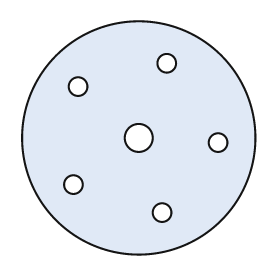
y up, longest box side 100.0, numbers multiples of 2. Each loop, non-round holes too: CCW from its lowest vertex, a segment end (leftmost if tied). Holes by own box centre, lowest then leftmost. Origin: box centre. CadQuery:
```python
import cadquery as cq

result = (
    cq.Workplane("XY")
    .moveTo(0.0, 0.0)
    .circle(50.0)
    .moveTo(10.0, -32.0)
    .circle(4.0)
    .moveTo(-28.0, -20.0)
    .circle(4.0)
    .moveTo(34.0, -2.0)
    .circle(4.0)
    .moveTo(0.0, 0.0)
    .circle(6.0)
    .moveTo(-26.0, 22.0)
    .circle(4.0)
    .moveTo(12.0, 32.0)
    .circle(4.0)
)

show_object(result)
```